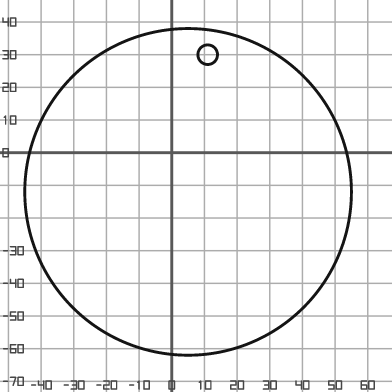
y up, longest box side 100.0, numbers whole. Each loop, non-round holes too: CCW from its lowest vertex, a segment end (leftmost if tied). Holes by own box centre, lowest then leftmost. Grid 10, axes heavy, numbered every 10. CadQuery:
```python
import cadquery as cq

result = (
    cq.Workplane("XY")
    .moveTo(5.0, -12.0)
    .circle(50.0)
    .moveTo(11.0, 30.0)
    .circle(3.0)
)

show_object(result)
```